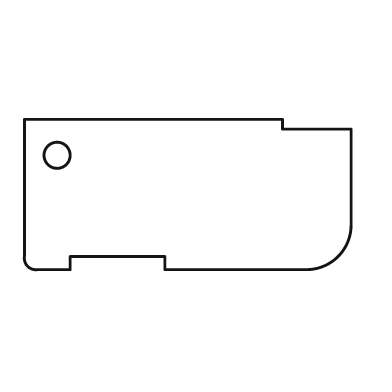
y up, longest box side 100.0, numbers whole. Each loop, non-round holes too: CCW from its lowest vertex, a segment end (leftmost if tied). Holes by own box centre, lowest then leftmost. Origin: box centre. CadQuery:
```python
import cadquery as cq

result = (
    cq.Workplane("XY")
    .moveTo(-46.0, -23.0)
    .lineTo(-36.0, -23.0)
    .lineTo(-36.0, -19.0)
    .lineTo(-7.0, -19.0)
    .lineTo(-7.0, -23.0)
    .lineTo(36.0, -23.0)
    .threePointArc((46.0, -19.0), (50.0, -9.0))
    .lineTo(50.0, 20.0)
    .lineTo(29.0, 20.0)
    .lineTo(29.0, 23.0)
    .lineTo(-50.0, 23.0)
    .lineTo(-50.0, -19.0)
    .threePointArc((-49.0, -22.0), (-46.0, -23.0))
    .close()
    .moveTo(-40.0, 12.0)
    .circle(4.0)
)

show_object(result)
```